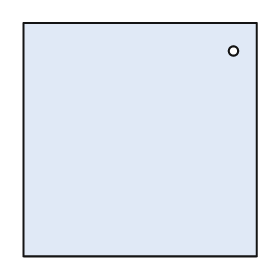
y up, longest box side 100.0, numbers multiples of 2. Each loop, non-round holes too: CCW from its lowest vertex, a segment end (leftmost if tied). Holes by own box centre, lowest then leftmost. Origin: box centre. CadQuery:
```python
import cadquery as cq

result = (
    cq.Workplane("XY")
    .moveTo(-50.0, -50.0)
    .lineTo(50.0, -50.0)
    .lineTo(50.0, 50.0)
    .lineTo(-50.0, 50.0)
    .close()
    .moveTo(40.0, 38.0)
    .circle(2.0)
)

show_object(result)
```